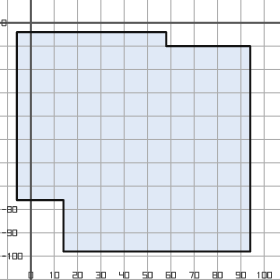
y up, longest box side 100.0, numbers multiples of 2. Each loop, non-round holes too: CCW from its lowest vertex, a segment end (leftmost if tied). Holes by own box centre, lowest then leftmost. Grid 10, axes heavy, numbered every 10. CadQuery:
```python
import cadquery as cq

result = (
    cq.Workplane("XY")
    .moveTo(14.0, -98.0)
    .lineTo(94.0, -98.0)
    .lineTo(94.0, -10.0)
    .lineTo(58.0, -10.0)
    .lineTo(58.0, -4.0)
    .lineTo(-6.0, -4.0)
    .lineTo(-6.0, -76.0)
    .lineTo(14.0, -76.0)
    .close()
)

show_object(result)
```